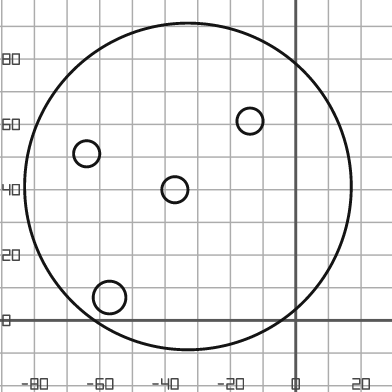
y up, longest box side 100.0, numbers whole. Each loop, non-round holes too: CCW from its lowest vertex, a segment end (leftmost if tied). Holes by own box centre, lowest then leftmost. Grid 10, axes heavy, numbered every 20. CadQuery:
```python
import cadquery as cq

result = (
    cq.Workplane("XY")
    .moveTo(-33.0, 41.0)
    .circle(50.0)
    .moveTo(-57.0, 7.0)
    .circle(5.0)
    .moveTo(-37.0, 40.0)
    .circle(4.0)
    .moveTo(-64.0, 51.0)
    .circle(4.0)
    .moveTo(-14.0, 61.0)
    .circle(4.0)
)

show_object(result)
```